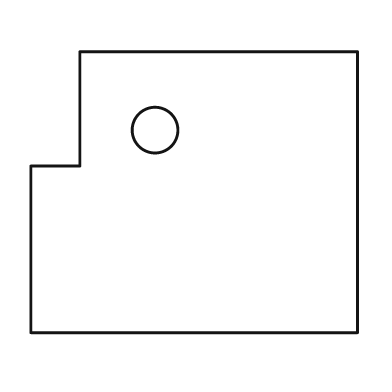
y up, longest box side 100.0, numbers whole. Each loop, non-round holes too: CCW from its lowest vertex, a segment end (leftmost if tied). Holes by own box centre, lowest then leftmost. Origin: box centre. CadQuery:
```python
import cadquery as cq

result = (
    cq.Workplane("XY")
    .moveTo(-50.0, -43.0)
    .lineTo(50.0, -43.0)
    .lineTo(50.0, 43.0)
    .lineTo(-35.0, 43.0)
    .lineTo(-35.0, 8.0)
    .lineTo(-50.0, 8.0)
    .close()
    .moveTo(-12.0, 19.0)
    .circle(7.0)
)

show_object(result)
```